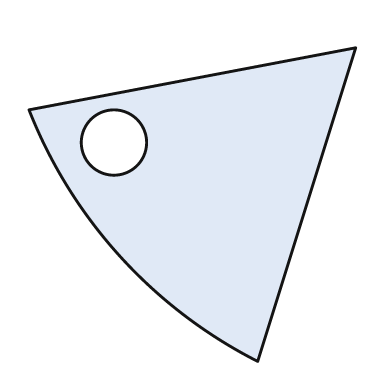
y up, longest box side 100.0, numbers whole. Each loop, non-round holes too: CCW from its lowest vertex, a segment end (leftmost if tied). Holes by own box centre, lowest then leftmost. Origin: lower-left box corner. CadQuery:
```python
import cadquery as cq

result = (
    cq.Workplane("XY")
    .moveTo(70.0, 0.0)
    .lineTo(100.0, 96.0)
    .lineTo(0.0, 77.0)
    .threePointArc((28.0, 32.0), (70.0, 0.0))
    .close()
    .moveTo(26.0, 67.0)
    .circle(10.0)
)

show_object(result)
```